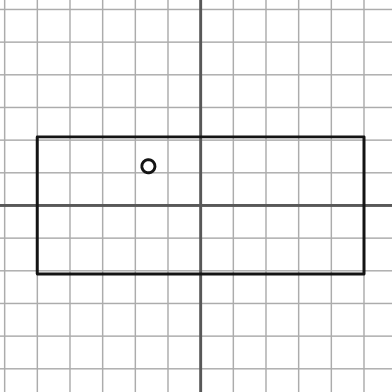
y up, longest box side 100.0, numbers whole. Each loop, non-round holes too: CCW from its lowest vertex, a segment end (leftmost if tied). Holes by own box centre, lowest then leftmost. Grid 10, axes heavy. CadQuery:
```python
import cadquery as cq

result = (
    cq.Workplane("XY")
    .moveTo(-50.0, -21.0)
    .lineTo(50.0, -21.0)
    .lineTo(50.0, 21.0)
    .lineTo(-50.0, 21.0)
    .close()
    .moveTo(-16.0, 12.0)
    .circle(2.0)
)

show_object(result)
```